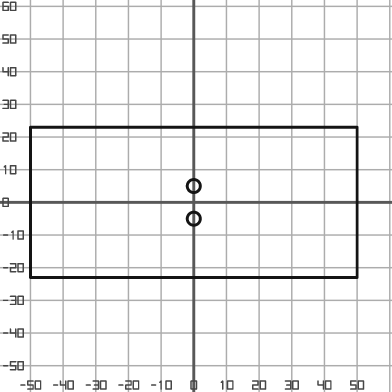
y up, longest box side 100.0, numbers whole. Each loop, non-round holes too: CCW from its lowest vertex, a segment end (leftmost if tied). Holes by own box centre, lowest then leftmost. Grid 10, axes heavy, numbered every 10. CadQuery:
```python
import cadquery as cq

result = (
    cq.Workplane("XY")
    .moveTo(-50.0, -23.0)
    .lineTo(50.0, -23.0)
    .lineTo(50.0, 23.0)
    .lineTo(-50.0, 23.0)
    .close()
    .moveTo(0.0, -5.0)
    .circle(2.0)
    .moveTo(0.0, 5.0)
    .circle(2.0)
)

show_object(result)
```